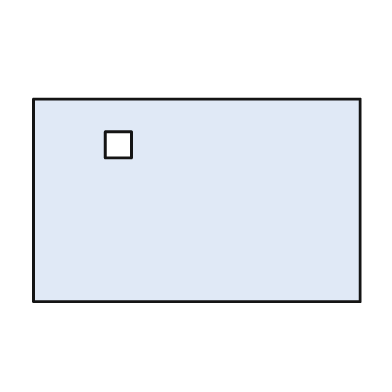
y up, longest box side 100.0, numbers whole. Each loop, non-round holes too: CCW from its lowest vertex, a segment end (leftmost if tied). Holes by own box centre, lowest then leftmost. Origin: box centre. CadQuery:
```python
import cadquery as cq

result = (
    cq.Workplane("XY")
    .moveTo(-50.0, -31.0)
    .lineTo(50.0, -31.0)
    .lineTo(50.0, 31.0)
    .lineTo(-50.0, 31.0)
    .close()
    .moveTo(-28.0, 13.0)
    .lineTo(-20.0, 13.0)
    .lineTo(-20.0, 21.0)
    .lineTo(-28.0, 21.0)
    .close()
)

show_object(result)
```